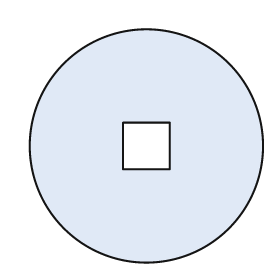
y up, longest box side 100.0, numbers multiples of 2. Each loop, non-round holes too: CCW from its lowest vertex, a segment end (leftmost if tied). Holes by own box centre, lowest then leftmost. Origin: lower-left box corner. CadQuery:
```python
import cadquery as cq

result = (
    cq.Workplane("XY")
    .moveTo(50.0, 50.0)
    .circle(50.0)
    .moveTo(40.0, 40.0)
    .lineTo(60.0, 40.0)
    .lineTo(60.0, 60.0)
    .lineTo(40.0, 60.0)
    .close()
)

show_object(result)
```